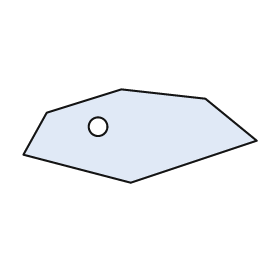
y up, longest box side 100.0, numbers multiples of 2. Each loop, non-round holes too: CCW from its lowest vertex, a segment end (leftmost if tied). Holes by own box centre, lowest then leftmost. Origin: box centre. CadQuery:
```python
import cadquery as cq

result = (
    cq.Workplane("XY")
    .moveTo(-4.0, -20.0)
    .lineTo(50.0, -2.0)
    .lineTo(28.0, 16.0)
    .lineTo(-8.0, 20.0)
    .lineTo(-40.0, 10.0)
    .lineTo(-50.0, -8.0)
    .close()
    .moveTo(-18.0, 4.0)
    .circle(4.0)
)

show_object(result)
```